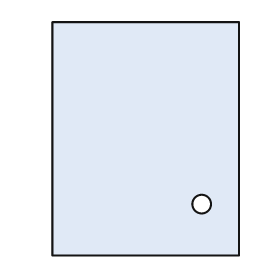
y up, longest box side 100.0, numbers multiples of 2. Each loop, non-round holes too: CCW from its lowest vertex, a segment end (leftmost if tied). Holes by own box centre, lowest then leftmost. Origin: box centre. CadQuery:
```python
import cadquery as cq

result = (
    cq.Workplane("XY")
    .moveTo(-40.0, -50.0)
    .lineTo(40.0, -50.0)
    .lineTo(40.0, 50.0)
    .lineTo(-40.0, 50.0)
    .close()
    .moveTo(24.0, -28.0)
    .circle(4.0)
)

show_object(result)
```